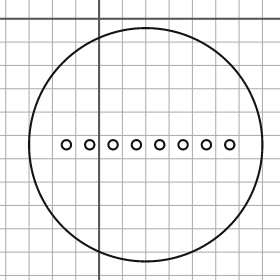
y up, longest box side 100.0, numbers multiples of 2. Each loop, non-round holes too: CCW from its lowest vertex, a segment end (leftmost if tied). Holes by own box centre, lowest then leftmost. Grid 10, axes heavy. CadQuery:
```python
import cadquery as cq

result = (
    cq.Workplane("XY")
    .moveTo(20.0, -54.0)
    .circle(50.0)
    .moveTo(-14.0, -54.0)
    .circle(2.0)
    .moveTo(-4.0, -54.0)
    .circle(2.0)
    .moveTo(6.0, -54.0)
    .circle(2.0)
    .moveTo(16.0, -54.0)
    .circle(2.0)
    .moveTo(26.0, -54.0)
    .circle(2.0)
    .moveTo(36.0, -54.0)
    .circle(2.0)
    .moveTo(46.0, -54.0)
    .circle(2.0)
    .moveTo(56.0, -54.0)
    .circle(2.0)
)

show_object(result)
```